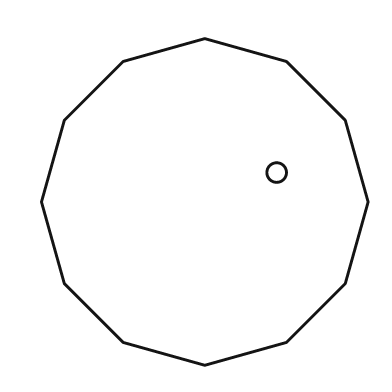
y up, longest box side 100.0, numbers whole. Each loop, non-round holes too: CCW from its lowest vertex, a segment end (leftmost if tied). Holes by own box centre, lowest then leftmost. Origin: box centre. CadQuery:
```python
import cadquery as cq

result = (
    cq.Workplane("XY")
    .moveTo(0.0, -50.0)
    .lineTo(25.0, -43.0)
    .lineTo(43.0, -25.0)
    .lineTo(50.0, 0.0)
    .lineTo(43.0, 25.0)
    .lineTo(25.0, 43.0)
    .lineTo(0.0, 50.0)
    .lineTo(-25.0, 43.0)
    .lineTo(-43.0, 25.0)
    .lineTo(-50.0, 0.0)
    .lineTo(-43.0, -25.0)
    .lineTo(-25.0, -43.0)
    .close()
    .moveTo(22.0, 9.0)
    .circle(3.0)
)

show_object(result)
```